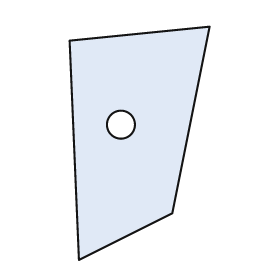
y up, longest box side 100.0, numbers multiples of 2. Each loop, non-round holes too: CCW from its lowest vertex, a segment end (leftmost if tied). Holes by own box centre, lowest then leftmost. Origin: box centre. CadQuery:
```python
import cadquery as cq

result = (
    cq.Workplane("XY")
    .moveTo(-26.0, -50.0)
    .lineTo(14.0, -30.0)
    .lineTo(30.0, 50.0)
    .lineTo(-30.0, 44.0)
    .close()
    .moveTo(-8.0, 8.0)
    .circle(6.0)
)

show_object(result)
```